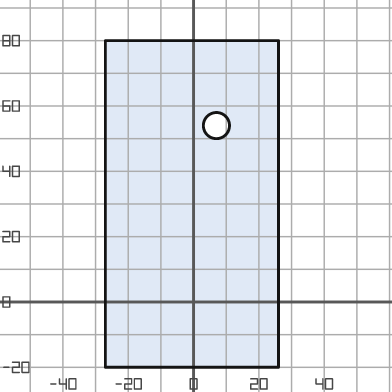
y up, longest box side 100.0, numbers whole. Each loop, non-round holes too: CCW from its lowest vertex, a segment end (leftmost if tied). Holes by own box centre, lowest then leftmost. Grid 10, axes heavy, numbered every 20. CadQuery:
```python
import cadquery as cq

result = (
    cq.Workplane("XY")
    .moveTo(-27.0, -20.0)
    .lineTo(26.0, -20.0)
    .lineTo(26.0, 80.0)
    .lineTo(-27.0, 80.0)
    .close()
    .moveTo(7.0, 54.0)
    .circle(4.0)
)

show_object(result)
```